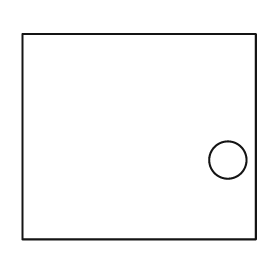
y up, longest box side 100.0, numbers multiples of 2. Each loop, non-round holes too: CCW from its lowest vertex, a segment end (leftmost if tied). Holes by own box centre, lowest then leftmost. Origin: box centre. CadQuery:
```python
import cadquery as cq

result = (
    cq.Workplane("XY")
    .moveTo(-50.0, -44.0)
    .lineTo(50.0, -44.0)
    .lineTo(50.0, 44.0)
    .lineTo(-50.0, 44.0)
    .close()
    .moveTo(38.0, -10.0)
    .circle(8.0)
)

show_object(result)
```